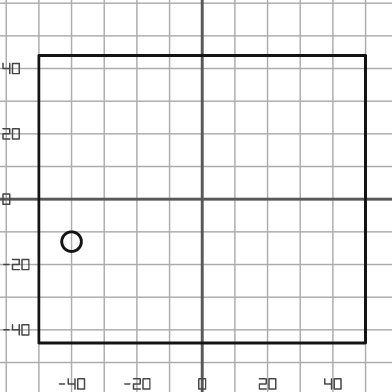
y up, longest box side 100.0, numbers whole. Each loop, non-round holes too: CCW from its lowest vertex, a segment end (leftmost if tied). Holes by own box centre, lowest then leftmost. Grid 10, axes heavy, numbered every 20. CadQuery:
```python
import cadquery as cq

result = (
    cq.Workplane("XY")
    .moveTo(-50.0, -44.0)
    .lineTo(50.0, -44.0)
    .lineTo(50.0, 44.0)
    .lineTo(-50.0, 44.0)
    .close()
    .moveTo(-40.0, -13.0)
    .circle(3.0)
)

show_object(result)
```